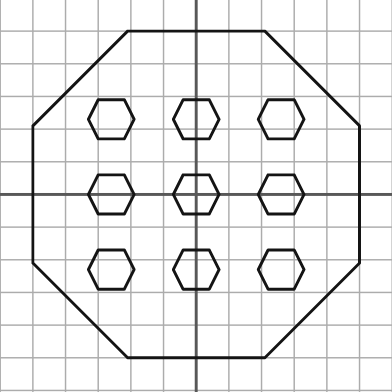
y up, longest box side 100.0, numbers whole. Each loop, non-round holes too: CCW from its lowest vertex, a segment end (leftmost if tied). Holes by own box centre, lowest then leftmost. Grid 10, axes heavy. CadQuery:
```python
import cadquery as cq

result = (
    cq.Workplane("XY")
    .moveTo(-21.0, -50.0)
    .lineTo(21.0, -50.0)
    .lineTo(50.0, -21.0)
    .lineTo(50.0, 21.0)
    .lineTo(21.0, 50.0)
    .lineTo(-21.0, 50.0)
    .lineTo(-50.0, 21.0)
    .lineTo(-50.0, -21.0)
    .close()
    .moveTo(-30.0, -29.0)
    .lineTo(-22.0, -29.0)
    .lineTo(-19.0, -23.0)
    .lineTo(-22.0, -17.0)
    .lineTo(-30.0, -17.0)
    .lineTo(-33.0, -23.0)
    .close()
    .moveTo(-4.0, -29.0)
    .lineTo(4.0, -29.0)
    .lineTo(7.0, -23.0)
    .lineTo(4.0, -17.0)
    .lineTo(-4.0, -17.0)
    .lineTo(-7.0, -23.0)
    .close()
    .moveTo(22.0, -29.0)
    .lineTo(30.0, -29.0)
    .lineTo(33.0, -23.0)
    .lineTo(30.0, -17.0)
    .lineTo(22.0, -17.0)
    .lineTo(19.0, -23.0)
    .close()
    .moveTo(-30.0, -6.0)
    .lineTo(-22.0, -6.0)
    .lineTo(-19.0, 0.0)
    .lineTo(-22.0, 6.0)
    .lineTo(-30.0, 6.0)
    .lineTo(-33.0, 0.0)
    .close()
    .moveTo(-4.0, -6.0)
    .lineTo(4.0, -6.0)
    .lineTo(7.0, 0.0)
    .lineTo(4.0, 6.0)
    .lineTo(-4.0, 6.0)
    .lineTo(-7.0, 0.0)
    .close()
    .moveTo(22.0, -6.0)
    .lineTo(30.0, -6.0)
    .lineTo(33.0, 0.0)
    .lineTo(30.0, 6.0)
    .lineTo(22.0, 6.0)
    .lineTo(19.0, 0.0)
    .close()
    .moveTo(-30.0, 17.0)
    .lineTo(-22.0, 17.0)
    .lineTo(-19.0, 23.0)
    .lineTo(-22.0, 29.0)
    .lineTo(-30.0, 29.0)
    .lineTo(-33.0, 23.0)
    .close()
    .moveTo(-4.0, 17.0)
    .lineTo(4.0, 17.0)
    .lineTo(7.0, 23.0)
    .lineTo(4.0, 29.0)
    .lineTo(-4.0, 29.0)
    .lineTo(-7.0, 23.0)
    .close()
    .moveTo(22.0, 17.0)
    .lineTo(30.0, 17.0)
    .lineTo(33.0, 23.0)
    .lineTo(30.0, 29.0)
    .lineTo(22.0, 29.0)
    .lineTo(19.0, 23.0)
    .close()
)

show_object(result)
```